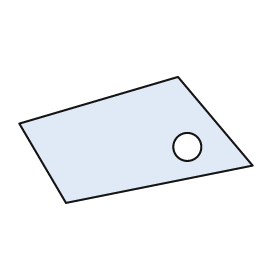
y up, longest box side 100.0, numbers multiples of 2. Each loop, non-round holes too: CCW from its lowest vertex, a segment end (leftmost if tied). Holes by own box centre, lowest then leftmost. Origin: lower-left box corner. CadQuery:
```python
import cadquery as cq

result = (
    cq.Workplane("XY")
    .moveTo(20.0, 0.0)
    .lineTo(100.0, 16.0)
    .lineTo(68.0, 54.0)
    .lineTo(0.0, 34.0)
    .close()
    .moveTo(72.0, 24.0)
    .circle(6.0)
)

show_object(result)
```